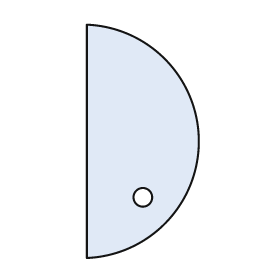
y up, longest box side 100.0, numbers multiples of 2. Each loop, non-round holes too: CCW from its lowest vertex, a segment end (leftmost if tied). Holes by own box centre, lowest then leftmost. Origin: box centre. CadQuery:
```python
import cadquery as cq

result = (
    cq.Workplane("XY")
    .moveTo(-24.0, -50.0)
    .threePointArc((24.0, 0.0), (-24.0, 50.0))
    .close()
    .moveTo(0.0, -24.0)
    .circle(4.0)
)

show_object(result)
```